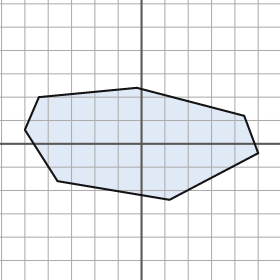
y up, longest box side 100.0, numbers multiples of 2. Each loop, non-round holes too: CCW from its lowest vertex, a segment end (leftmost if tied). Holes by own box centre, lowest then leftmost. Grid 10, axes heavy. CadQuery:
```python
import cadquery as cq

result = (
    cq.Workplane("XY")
    .moveTo(12.0, -24.0)
    .lineTo(50.0, -4.0)
    .lineTo(44.0, 12.0)
    .lineTo(-2.0, 24.0)
    .lineTo(-44.0, 20.0)
    .lineTo(-50.0, 6.0)
    .lineTo(-36.0, -16.0)
    .close()
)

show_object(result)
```